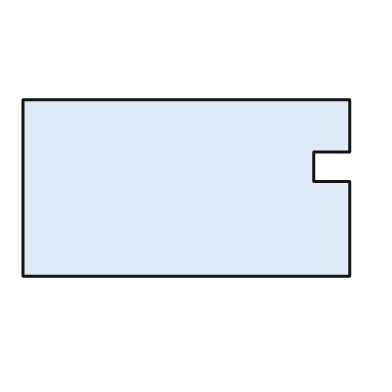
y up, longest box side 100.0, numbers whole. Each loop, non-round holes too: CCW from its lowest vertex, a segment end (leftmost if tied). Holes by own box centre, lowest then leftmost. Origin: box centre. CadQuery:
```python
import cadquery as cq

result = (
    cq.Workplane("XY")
    .moveTo(-50.0, -27.0)
    .lineTo(50.0, -27.0)
    .lineTo(50.0, 2.0)
    .lineTo(39.0, 2.0)
    .lineTo(39.0, 11.0)
    .lineTo(50.0, 11.0)
    .lineTo(50.0, 27.0)
    .lineTo(-50.0, 27.0)
    .close()
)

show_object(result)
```